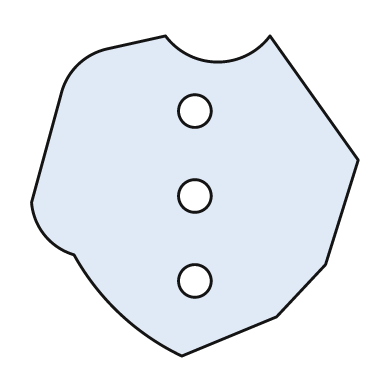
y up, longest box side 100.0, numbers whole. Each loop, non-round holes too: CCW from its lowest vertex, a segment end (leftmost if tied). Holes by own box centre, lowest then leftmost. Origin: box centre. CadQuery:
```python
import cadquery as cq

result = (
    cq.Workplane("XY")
    .moveTo(-4.0, -49.0)
    .lineTo(25.0, -37.0)
    .lineTo(40.0, -21.0)
    .lineTo(50.0, 11.0)
    .lineTo(23.0, 49.0)
    .threePointArc((7.0, 41.0), (-9.0, 49.0))
    .lineTo(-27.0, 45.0)
    .threePointArc((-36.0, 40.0), (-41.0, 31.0))
    .lineTo(-50.0, -2.0)
    .threePointArc((-46.0, -12.0), (-37.0, -18.0))
    .threePointArc((-23.0, -36.0), (-4.0, -49.0))
    .close()
    .moveTo(0.0, -26.0)
    .circle(5.0)
    .moveTo(0.0, 0.0)
    .circle(5.0)
    .moveTo(0.0, 26.0)
    .circle(5.0)
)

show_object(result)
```